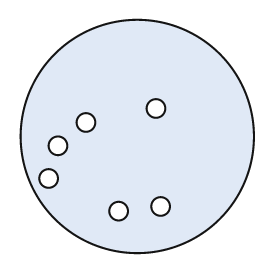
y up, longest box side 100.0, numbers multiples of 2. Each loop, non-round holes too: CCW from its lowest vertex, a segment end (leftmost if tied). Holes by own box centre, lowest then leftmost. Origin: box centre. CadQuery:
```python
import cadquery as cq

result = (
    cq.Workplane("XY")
    .moveTo(0.0, 0.0)
    .circle(50.0)
    .moveTo(-8.0, -32.0)
    .circle(4.0)
    .moveTo(10.0, -30.0)
    .circle(4.0)
    .moveTo(-38.0, -18.0)
    .circle(4.0)
    .moveTo(-34.0, -4.0)
    .circle(4.0)
    .moveTo(-22.0, 6.0)
    .circle(4.0)
    .moveTo(8.0, 12.0)
    .circle(4.0)
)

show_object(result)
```